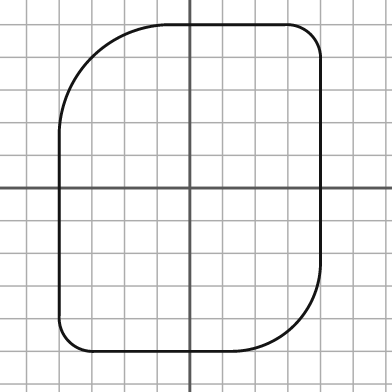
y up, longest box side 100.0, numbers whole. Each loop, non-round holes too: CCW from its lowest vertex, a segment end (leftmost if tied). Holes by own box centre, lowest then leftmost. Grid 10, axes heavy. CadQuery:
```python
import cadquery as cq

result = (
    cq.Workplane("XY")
    .moveTo(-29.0, -50.0)
    .lineTo(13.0, -50.0)
    .threePointArc((32.0, -42.0), (40.0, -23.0))
    .lineTo(40.0, 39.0)
    .threePointArc((37.0, 47.0), (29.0, 50.0))
    .lineTo(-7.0, 50.0)
    .threePointArc((-30.0, 40.0), (-40.0, 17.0))
    .lineTo(-40.0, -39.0)
    .threePointArc((-37.0, -47.0), (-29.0, -50.0))
    .close()
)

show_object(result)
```